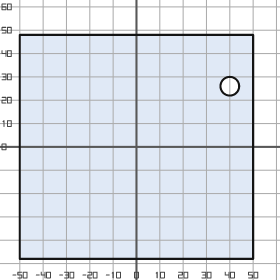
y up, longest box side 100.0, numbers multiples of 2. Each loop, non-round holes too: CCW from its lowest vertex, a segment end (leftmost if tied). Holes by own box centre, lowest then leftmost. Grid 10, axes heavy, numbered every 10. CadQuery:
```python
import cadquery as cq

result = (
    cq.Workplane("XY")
    .moveTo(-50.0, -48.0)
    .lineTo(50.0, -48.0)
    .lineTo(50.0, 48.0)
    .lineTo(-50.0, 48.0)
    .close()
    .moveTo(40.0, 26.0)
    .circle(4.0)
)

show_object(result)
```